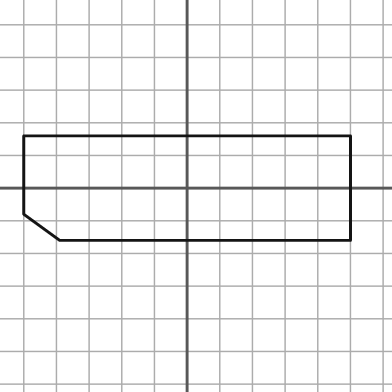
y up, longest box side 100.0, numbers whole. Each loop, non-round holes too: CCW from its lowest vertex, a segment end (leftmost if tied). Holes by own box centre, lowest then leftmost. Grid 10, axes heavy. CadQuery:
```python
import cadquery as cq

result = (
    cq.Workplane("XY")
    .moveTo(-39.0, -16.0)
    .lineTo(50.0, -16.0)
    .lineTo(50.0, 16.0)
    .lineTo(-50.0, 16.0)
    .lineTo(-50.0, -8.0)
    .close()
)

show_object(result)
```